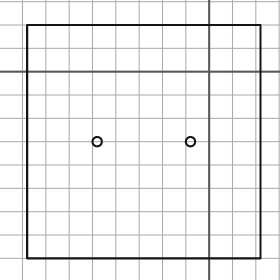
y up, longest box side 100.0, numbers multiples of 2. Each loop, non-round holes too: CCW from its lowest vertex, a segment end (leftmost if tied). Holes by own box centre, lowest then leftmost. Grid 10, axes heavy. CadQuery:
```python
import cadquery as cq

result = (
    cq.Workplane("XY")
    .moveTo(-78.0, -80.0)
    .lineTo(22.0, -80.0)
    .lineTo(22.0, 20.0)
    .lineTo(-78.0, 20.0)
    .close()
    .moveTo(-48.0, -30.0)
    .circle(2.0)
    .moveTo(-8.0, -30.0)
    .circle(2.0)
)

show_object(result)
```